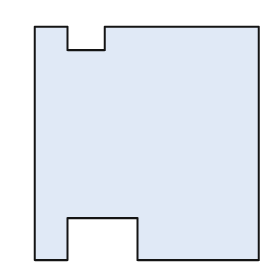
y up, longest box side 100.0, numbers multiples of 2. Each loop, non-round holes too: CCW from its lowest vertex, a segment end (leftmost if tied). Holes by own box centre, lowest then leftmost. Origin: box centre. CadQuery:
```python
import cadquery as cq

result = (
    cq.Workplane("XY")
    .moveTo(-48.0, -50.0)
    .lineTo(-34.0, -50.0)
    .lineTo(-34.0, -32.0)
    .lineTo(-4.0, -32.0)
    .lineTo(-4.0, -50.0)
    .lineTo(48.0, -50.0)
    .lineTo(48.0, 50.0)
    .lineTo(-18.0, 50.0)
    .lineTo(-18.0, 40.0)
    .lineTo(-34.0, 40.0)
    .lineTo(-34.0, 50.0)
    .lineTo(-48.0, 50.0)
    .close()
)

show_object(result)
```